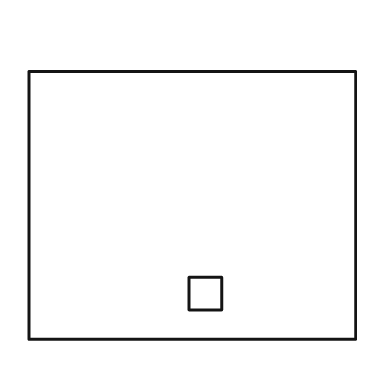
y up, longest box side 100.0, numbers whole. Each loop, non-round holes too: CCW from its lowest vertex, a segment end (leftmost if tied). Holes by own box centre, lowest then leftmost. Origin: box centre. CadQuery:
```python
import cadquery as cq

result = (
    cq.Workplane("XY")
    .moveTo(-50.0, -41.0)
    .lineTo(50.0, -41.0)
    .lineTo(50.0, 41.0)
    .lineTo(-50.0, 41.0)
    .close()
    .moveTo(-1.0, -32.0)
    .lineTo(9.0, -32.0)
    .lineTo(9.0, -22.0)
    .lineTo(-1.0, -22.0)
    .close()
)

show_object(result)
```